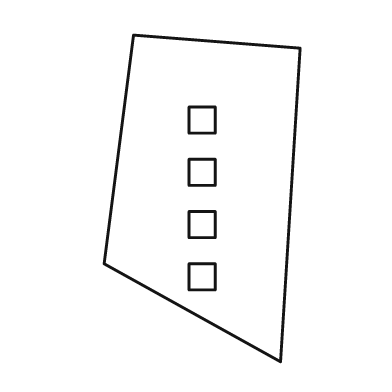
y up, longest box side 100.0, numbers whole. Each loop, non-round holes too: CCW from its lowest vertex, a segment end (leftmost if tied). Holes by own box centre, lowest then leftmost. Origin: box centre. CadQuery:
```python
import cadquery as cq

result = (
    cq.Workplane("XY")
    .moveTo(24.0, -50.0)
    .lineTo(30.0, 46.0)
    .lineTo(-21.0, 50.0)
    .lineTo(-30.0, -20.0)
    .close()
    .moveTo(-4.0, -28.0)
    .lineTo(4.0, -28.0)
    .lineTo(4.0, -20.0)
    .lineTo(-4.0, -20.0)
    .close()
    .moveTo(-4.0, -12.0)
    .lineTo(4.0, -12.0)
    .lineTo(4.0, -4.0)
    .lineTo(-4.0, -4.0)
    .close()
    .moveTo(-4.0, 4.0)
    .lineTo(4.0, 4.0)
    .lineTo(4.0, 12.0)
    .lineTo(-4.0, 12.0)
    .close()
    .moveTo(-4.0, 20.0)
    .lineTo(4.0, 20.0)
    .lineTo(4.0, 28.0)
    .lineTo(-4.0, 28.0)
    .close()
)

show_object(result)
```